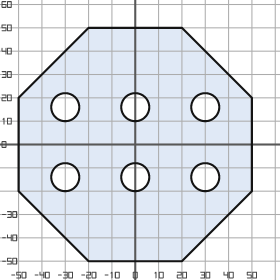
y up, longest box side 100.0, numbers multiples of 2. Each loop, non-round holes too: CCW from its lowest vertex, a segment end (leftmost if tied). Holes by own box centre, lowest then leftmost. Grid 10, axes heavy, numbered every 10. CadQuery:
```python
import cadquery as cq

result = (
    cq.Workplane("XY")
    .moveTo(-20.0, -50.0)
    .lineTo(20.0, -50.0)
    .lineTo(50.0, -20.0)
    .lineTo(50.0, 20.0)
    .lineTo(20.0, 50.0)
    .lineTo(-20.0, 50.0)
    .lineTo(-50.0, 20.0)
    .lineTo(-50.0, -20.0)
    .close()
    .moveTo(-30.0, -14.0)
    .circle(6.0)
    .moveTo(0.0, -14.0)
    .circle(6.0)
    .moveTo(30.0, -14.0)
    .circle(6.0)
    .moveTo(-30.0, 16.0)
    .circle(6.0)
    .moveTo(0.0, 16.0)
    .circle(6.0)
    .moveTo(30.0, 16.0)
    .circle(6.0)
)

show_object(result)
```